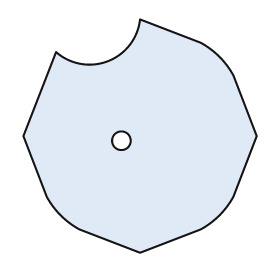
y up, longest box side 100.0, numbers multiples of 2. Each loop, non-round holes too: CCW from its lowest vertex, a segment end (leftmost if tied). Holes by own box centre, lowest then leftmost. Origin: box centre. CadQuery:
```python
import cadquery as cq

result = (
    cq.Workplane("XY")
    .moveTo(0.0, -50.0)
    .lineTo(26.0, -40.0)
    .threePointArc((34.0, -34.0), (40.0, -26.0))
    .lineTo(50.0, 0.0)
    .lineTo(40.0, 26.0)
    .threePointArc((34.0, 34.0), (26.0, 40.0))
    .lineTo(0.0, 50.0)
    .threePointArc((-14.0, 32.0), (-36.0, 36.0))
    .lineTo(-50.0, 0.0)
    .lineTo(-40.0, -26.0)
    .threePointArc((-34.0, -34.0), (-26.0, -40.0))
    .close()
    .moveTo(-8.0, -2.0)
    .circle(4.0)
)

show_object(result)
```